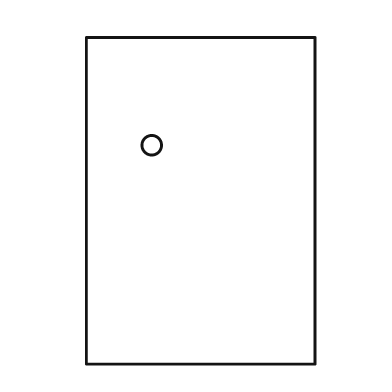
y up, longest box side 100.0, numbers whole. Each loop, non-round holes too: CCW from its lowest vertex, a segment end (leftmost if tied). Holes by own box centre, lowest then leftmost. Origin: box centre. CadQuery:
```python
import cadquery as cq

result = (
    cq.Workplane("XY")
    .moveTo(-35.0, -50.0)
    .lineTo(35.0, -50.0)
    .lineTo(35.0, 50.0)
    .lineTo(-35.0, 50.0)
    .close()
    .moveTo(-15.0, 17.0)
    .circle(3.0)
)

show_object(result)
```